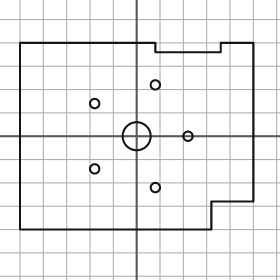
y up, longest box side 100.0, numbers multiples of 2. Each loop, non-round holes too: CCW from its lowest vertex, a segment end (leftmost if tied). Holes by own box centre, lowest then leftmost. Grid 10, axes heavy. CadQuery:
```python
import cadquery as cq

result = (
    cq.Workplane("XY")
    .moveTo(-50.0, -40.0)
    .lineTo(32.0, -40.0)
    .lineTo(32.0, -28.0)
    .lineTo(50.0, -28.0)
    .lineTo(50.0, 40.0)
    .lineTo(36.0, 40.0)
    .lineTo(36.0, 36.0)
    .lineTo(8.0, 36.0)
    .lineTo(8.0, 40.0)
    .lineTo(-50.0, 40.0)
    .close()
    .moveTo(8.0, -22.0)
    .circle(2.0)
    .moveTo(-18.0, -14.0)
    .circle(2.0)
    .moveTo(0.0, 0.0)
    .circle(6.0)
    .moveTo(22.0, 0.0)
    .circle(2.0)
    .moveTo(-18.0, 14.0)
    .circle(2.0)
    .moveTo(8.0, 22.0)
    .circle(2.0)
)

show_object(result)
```